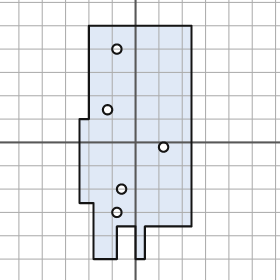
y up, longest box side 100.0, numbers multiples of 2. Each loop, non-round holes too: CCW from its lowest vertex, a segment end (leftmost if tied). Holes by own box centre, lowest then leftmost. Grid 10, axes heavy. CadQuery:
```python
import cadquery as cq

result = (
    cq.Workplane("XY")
    .moveTo(-18.0, -50.0)
    .lineTo(-8.0, -50.0)
    .lineTo(-8.0, -36.0)
    .lineTo(0.0, -36.0)
    .lineTo(0.0, -50.0)
    .lineTo(4.0, -50.0)
    .lineTo(4.0, -36.0)
    .lineTo(24.0, -36.0)
    .lineTo(24.0, 50.0)
    .lineTo(-20.0, 50.0)
    .lineTo(-20.0, 10.0)
    .lineTo(-24.0, 10.0)
    .lineTo(-24.0, -26.0)
    .lineTo(-18.0, -26.0)
    .close()
    .moveTo(-8.0, -30.0)
    .circle(2.0)
    .moveTo(-6.0, -20.0)
    .circle(2.0)
    .moveTo(12.0, -2.0)
    .circle(2.0)
    .moveTo(-12.0, 14.0)
    .circle(2.0)
    .moveTo(-8.0, 40.0)
    .circle(2.0)
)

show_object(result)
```